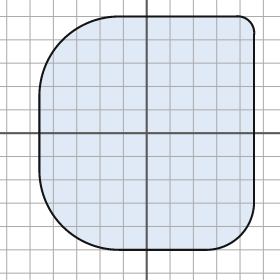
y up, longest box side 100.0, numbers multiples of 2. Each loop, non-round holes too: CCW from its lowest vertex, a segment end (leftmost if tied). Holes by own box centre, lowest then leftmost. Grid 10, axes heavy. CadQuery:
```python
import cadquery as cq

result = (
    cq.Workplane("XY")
    .moveTo(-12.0, -50.0)
    .lineTo(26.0, -50.0)
    .threePointArc((40.0, -44.0), (46.0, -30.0))
    .lineTo(46.0, 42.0)
    .threePointArc((44.0, 48.0), (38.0, 50.0))
    .lineTo(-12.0, 50.0)
    .threePointArc((-36.0, 40.0), (-46.0, 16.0))
    .lineTo(-46.0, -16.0)
    .threePointArc((-36.0, -40.0), (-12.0, -50.0))
    .close()
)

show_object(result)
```